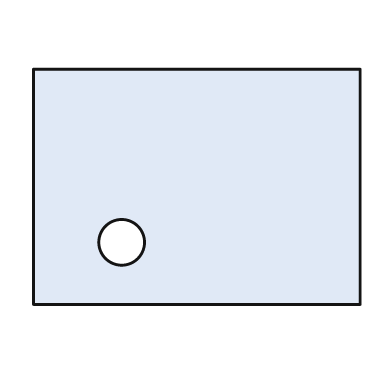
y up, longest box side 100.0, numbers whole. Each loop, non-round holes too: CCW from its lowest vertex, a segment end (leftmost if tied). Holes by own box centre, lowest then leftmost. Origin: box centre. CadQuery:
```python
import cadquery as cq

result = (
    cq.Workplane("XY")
    .moveTo(-50.0, -36.0)
    .lineTo(50.0, -36.0)
    .lineTo(50.0, 36.0)
    .lineTo(-50.0, 36.0)
    .close()
    .moveTo(-23.0, -17.0)
    .circle(7.0)
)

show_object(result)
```